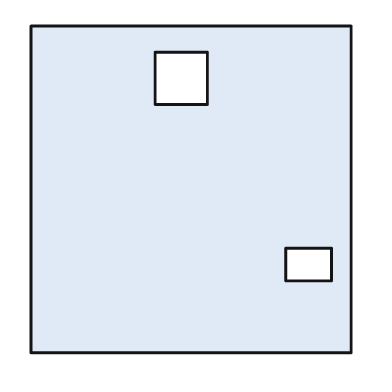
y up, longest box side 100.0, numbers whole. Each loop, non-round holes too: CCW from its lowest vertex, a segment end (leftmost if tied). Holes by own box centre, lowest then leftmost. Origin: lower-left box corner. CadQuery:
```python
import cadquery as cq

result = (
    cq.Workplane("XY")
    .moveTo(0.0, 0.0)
    .lineTo(98.0, 0.0)
    .lineTo(98.0, 100.0)
    .lineTo(0.0, 100.0)
    .close()
    .moveTo(78.0, 22.0)
    .lineTo(92.0, 22.0)
    .lineTo(92.0, 32.0)
    .lineTo(78.0, 32.0)
    .close()
    .moveTo(38.0, 76.0)
    .lineTo(54.0, 76.0)
    .lineTo(54.0, 92.0)
    .lineTo(38.0, 92.0)
    .close()
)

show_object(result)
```